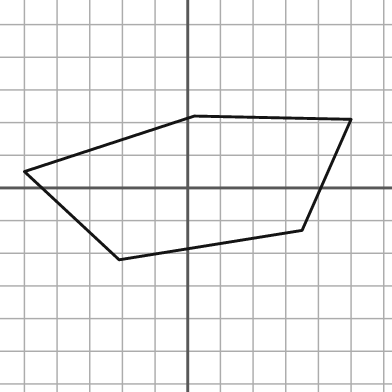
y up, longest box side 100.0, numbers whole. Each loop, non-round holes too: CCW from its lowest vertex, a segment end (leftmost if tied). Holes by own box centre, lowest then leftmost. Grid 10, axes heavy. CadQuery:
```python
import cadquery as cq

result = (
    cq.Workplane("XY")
    .moveTo(-21.0, -22.0)
    .lineTo(35.0, -13.0)
    .lineTo(50.0, 21.0)
    .lineTo(2.0, 22.0)
    .lineTo(-50.0, 5.0)
    .close()
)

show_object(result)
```